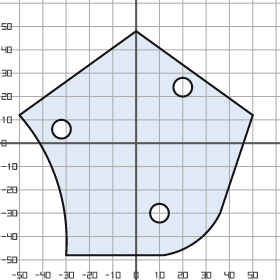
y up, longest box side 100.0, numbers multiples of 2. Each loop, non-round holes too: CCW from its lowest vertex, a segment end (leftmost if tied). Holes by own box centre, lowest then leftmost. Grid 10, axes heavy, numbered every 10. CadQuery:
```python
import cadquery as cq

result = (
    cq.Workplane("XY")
    .moveTo(-30.0, -48.0)
    .lineTo(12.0, -48.0)
    .threePointArc((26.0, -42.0), (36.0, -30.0))
    .lineTo(50.0, 12.0)
    .lineTo(0.0, 48.0)
    .lineTo(-50.0, 12.0)
    .threePointArc((-34.0, -16.0), (-30.0, -48.0))
    .close()
    .moveTo(10.0, -30.0)
    .circle(4.0)
    .moveTo(-32.0, 6.0)
    .circle(4.0)
    .moveTo(20.0, 24.0)
    .circle(4.0)
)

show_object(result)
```